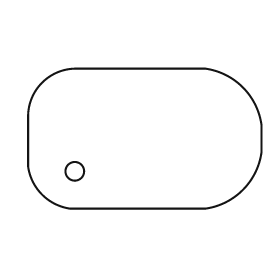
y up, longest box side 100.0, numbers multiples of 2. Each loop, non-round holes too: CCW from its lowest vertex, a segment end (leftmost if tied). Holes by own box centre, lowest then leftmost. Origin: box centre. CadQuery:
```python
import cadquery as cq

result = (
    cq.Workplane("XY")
    .moveTo(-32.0, -30.0)
    .lineTo(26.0, -30.0)
    .threePointArc((42.0, -22.0), (50.0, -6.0))
    .lineTo(50.0, 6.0)
    .threePointArc((42.0, 22.0), (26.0, 30.0))
    .lineTo(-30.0, 30.0)
    .threePointArc((-44.0, 24.0), (-50.0, 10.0))
    .lineTo(-50.0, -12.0)
    .threePointArc((-44.0, -24.0), (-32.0, -30.0))
    .close()
    .moveTo(-30.0, -14.0)
    .circle(4.0)
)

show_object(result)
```